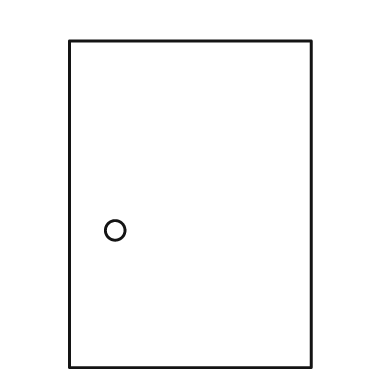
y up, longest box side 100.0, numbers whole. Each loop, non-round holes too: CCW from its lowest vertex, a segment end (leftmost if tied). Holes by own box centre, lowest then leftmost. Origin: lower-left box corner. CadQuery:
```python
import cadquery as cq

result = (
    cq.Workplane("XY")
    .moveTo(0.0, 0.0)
    .lineTo(74.0, 0.0)
    .lineTo(74.0, 100.0)
    .lineTo(0.0, 100.0)
    .close()
    .moveTo(14.0, 42.0)
    .circle(3.0)
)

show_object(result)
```